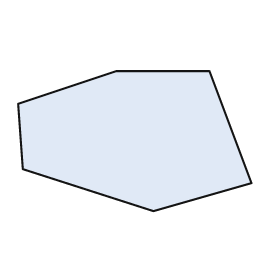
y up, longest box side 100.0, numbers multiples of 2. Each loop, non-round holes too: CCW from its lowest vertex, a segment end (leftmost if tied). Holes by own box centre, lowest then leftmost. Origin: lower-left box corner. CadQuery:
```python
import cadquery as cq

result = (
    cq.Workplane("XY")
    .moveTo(58.0, 0.0)
    .lineTo(100.0, 12.0)
    .lineTo(82.0, 60.0)
    .lineTo(42.0, 60.0)
    .lineTo(0.0, 46.0)
    .lineTo(2.0, 18.0)
    .close()
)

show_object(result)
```